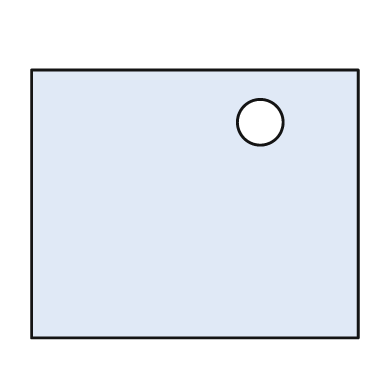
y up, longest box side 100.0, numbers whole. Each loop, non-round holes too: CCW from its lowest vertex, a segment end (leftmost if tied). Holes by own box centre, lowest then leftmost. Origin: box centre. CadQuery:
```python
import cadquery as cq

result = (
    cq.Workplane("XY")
    .moveTo(-50.0, -41.0)
    .lineTo(50.0, -41.0)
    .lineTo(50.0, 41.0)
    .lineTo(-50.0, 41.0)
    .close()
    .moveTo(20.0, 25.0)
    .circle(7.0)
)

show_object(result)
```